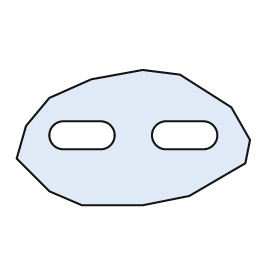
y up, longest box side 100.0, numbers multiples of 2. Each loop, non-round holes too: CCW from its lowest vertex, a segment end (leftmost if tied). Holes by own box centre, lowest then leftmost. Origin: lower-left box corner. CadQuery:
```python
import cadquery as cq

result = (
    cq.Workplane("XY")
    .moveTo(28.0, 0.0)
    .lineTo(54.0, 0.0)
    .lineTo(74.0, 4.0)
    .lineTo(98.0, 18.0)
    .lineTo(100.0, 28.0)
    .lineTo(92.0, 42.0)
    .lineTo(70.0, 56.0)
    .lineTo(54.0, 58.0)
    .lineTo(32.0, 54.0)
    .lineTo(14.0, 46.0)
    .lineTo(4.0, 34.0)
    .lineTo(0.0, 20.0)
    .lineTo(14.0, 6.0)
    .close()
    .moveTo(20.0, 24.0)
    .lineTo(36.0, 24.0)
    .threePointArc((42.0, 30.0), (36.0, 36.0))
    .lineTo(20.0, 36.0)
    .threePointArc((14.0, 30.0), (20.0, 24.0))
    .close()
    .moveTo(64.0, 24.0)
    .lineTo(80.0, 24.0)
    .threePointArc((86.0, 30.0), (80.0, 36.0))
    .lineTo(64.0, 36.0)
    .threePointArc((58.0, 30.0), (64.0, 24.0))
    .close()
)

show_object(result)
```